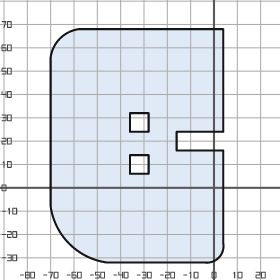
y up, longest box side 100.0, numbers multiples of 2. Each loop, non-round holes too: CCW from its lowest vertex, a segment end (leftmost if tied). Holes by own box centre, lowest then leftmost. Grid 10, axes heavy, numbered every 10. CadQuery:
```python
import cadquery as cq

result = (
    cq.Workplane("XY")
    .moveTo(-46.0, -32.0)
    .lineTo(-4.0, -32.0)
    .threePointArc((2.0, -30.0), (4.0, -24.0))
    .lineTo(4.0, 16.0)
    .lineTo(-16.0, 16.0)
    .lineTo(-16.0, 24.0)
    .lineTo(4.0, 24.0)
    .lineTo(4.0, 68.0)
    .lineTo(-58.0, 68.0)
    .threePointArc((-66.0, 64.0), (-70.0, 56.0))
    .lineTo(-70.0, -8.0)
    .threePointArc((-62.0, -24.0), (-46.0, -32.0))
    .close()
    .moveTo(-36.0, 6.0)
    .lineTo(-28.0, 6.0)
    .lineTo(-28.0, 14.0)
    .lineTo(-36.0, 14.0)
    .close()
    .moveTo(-36.0, 24.0)
    .lineTo(-28.0, 24.0)
    .lineTo(-28.0, 32.0)
    .lineTo(-36.0, 32.0)
    .close()
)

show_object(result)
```